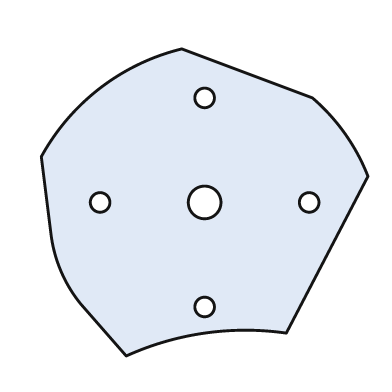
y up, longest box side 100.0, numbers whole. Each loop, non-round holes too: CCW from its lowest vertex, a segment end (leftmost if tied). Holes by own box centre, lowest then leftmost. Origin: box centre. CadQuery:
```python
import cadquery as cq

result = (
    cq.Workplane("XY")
    .moveTo(-24.0, -47.0)
    .threePointArc((0.0, -40.0), (25.0, -40.0))
    .lineTo(50.0, 8.0)
    .threePointArc((43.0, 21.0), (33.0, 32.0))
    .lineTo(-7.0, 47.0)
    .threePointArc((-32.0, 35.0), (-50.0, 14.0))
    .lineTo(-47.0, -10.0)
    .threePointArc((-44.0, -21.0), (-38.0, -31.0))
    .close()
    .moveTo(0.0, -32.0)
    .circle(3.0)
    .moveTo(-32.0, 0.0)
    .circle(3.0)
    .moveTo(0.0, 0.0)
    .circle(5.0)
    .moveTo(32.0, 0.0)
    .circle(3.0)
    .moveTo(0.0, 32.0)
    .circle(3.0)
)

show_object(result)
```